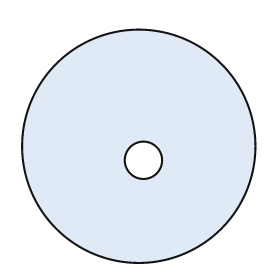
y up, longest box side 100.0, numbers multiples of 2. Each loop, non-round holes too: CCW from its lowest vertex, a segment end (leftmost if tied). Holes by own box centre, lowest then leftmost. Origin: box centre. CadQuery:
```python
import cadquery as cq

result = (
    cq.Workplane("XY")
    .moveTo(0.0, 0.0)
    .circle(50.0)
    .moveTo(2.0, -6.0)
    .circle(8.0)
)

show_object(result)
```